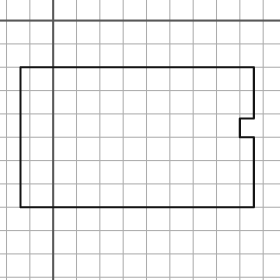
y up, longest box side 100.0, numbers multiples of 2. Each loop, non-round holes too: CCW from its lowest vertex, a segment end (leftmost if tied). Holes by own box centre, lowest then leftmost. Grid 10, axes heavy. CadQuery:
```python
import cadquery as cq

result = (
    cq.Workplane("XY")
    .moveTo(-14.0, -80.0)
    .lineTo(86.0, -80.0)
    .lineTo(86.0, -50.0)
    .lineTo(80.0, -50.0)
    .lineTo(80.0, -42.0)
    .lineTo(86.0, -42.0)
    .lineTo(86.0, -20.0)
    .lineTo(-14.0, -20.0)
    .close()
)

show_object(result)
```